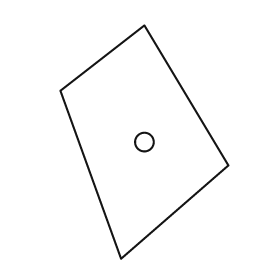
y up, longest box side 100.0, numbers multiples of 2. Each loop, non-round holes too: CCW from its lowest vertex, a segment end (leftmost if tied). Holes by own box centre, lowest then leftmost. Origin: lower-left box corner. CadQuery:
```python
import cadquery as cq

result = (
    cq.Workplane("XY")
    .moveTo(26.0, 0.0)
    .lineTo(72.0, 40.0)
    .lineTo(36.0, 100.0)
    .lineTo(0.0, 72.0)
    .close()
    .moveTo(36.0, 50.0)
    .circle(4.0)
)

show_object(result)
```